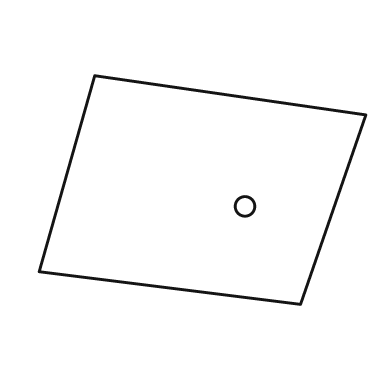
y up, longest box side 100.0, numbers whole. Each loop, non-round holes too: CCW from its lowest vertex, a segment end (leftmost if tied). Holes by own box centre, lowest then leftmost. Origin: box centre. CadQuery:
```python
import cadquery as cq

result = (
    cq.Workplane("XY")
    .moveTo(30.0, -35.0)
    .lineTo(50.0, 23.0)
    .lineTo(-33.0, 35.0)
    .lineTo(-50.0, -25.0)
    .close()
    .moveTo(13.0, -5.0)
    .circle(3.0)
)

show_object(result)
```